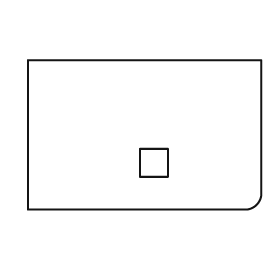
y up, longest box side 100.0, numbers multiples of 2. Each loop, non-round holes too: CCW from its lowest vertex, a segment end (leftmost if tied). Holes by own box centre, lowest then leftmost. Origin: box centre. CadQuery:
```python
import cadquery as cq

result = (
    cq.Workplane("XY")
    .moveTo(-50.0, -32.0)
    .lineTo(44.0, -32.0)
    .threePointArc((48.0, -30.0), (50.0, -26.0))
    .lineTo(50.0, 32.0)
    .lineTo(-50.0, 32.0)
    .close()
    .moveTo(-2.0, -18.0)
    .lineTo(10.0, -18.0)
    .lineTo(10.0, -6.0)
    .lineTo(-2.0, -6.0)
    .close()
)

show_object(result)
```